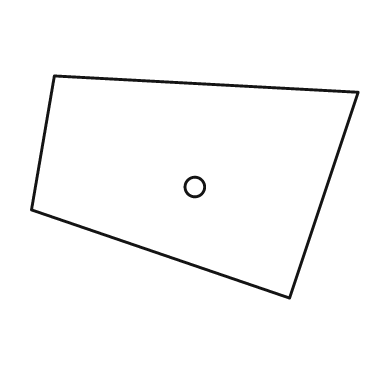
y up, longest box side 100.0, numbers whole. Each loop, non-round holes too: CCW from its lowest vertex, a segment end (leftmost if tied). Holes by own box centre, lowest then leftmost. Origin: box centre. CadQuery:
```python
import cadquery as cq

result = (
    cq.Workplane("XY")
    .moveTo(29.0, -34.0)
    .lineTo(50.0, 29.0)
    .lineTo(-43.0, 34.0)
    .lineTo(-50.0, -7.0)
    .close()
    .moveTo(0.0, 0.0)
    .circle(3.0)
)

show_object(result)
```